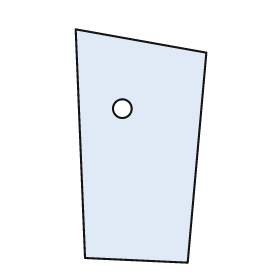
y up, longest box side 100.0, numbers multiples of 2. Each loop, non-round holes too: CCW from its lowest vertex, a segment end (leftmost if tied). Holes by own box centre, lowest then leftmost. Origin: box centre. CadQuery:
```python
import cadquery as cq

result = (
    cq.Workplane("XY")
    .moveTo(20.0, -50.0)
    .lineTo(28.0, 40.0)
    .lineTo(-28.0, 50.0)
    .lineTo(-24.0, -48.0)
    .close()
    .moveTo(-8.0, 16.0)
    .circle(4.0)
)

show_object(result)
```